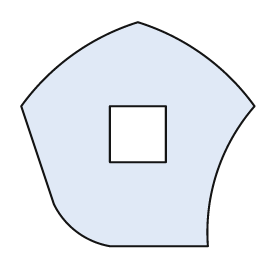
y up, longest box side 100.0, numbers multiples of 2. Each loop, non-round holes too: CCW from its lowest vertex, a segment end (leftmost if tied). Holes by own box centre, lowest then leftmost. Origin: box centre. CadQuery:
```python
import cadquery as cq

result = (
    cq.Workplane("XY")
    .moveTo(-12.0, -48.0)
    .lineTo(30.0, -48.0)
    .threePointArc((34.0, -16.0), (50.0, 12.0))
    .threePointArc((28.0, 34.0), (0.0, 48.0))
    .threePointArc((-28.0, 34.0), (-50.0, 12.0))
    .lineTo(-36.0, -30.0)
    .threePointArc((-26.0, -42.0), (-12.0, -48.0))
    .close()
    .moveTo(-12.0, -12.0)
    .lineTo(12.0, -12.0)
    .lineTo(12.0, 12.0)
    .lineTo(-12.0, 12.0)
    .close()
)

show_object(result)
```